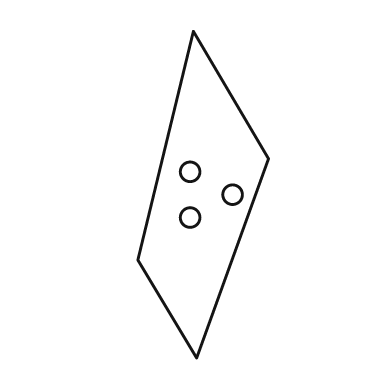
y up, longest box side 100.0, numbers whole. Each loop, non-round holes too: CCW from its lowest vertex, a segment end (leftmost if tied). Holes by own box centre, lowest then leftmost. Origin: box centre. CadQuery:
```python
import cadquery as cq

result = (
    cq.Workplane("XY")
    .moveTo(-2.0, -50.0)
    .lineTo(20.0, 11.0)
    .lineTo(-3.0, 50.0)
    .lineTo(-20.0, -20.0)
    .close()
    .moveTo(-4.0, -7.0)
    .circle(3.0)
    .moveTo(9.0, 0.0)
    .circle(3.0)
    .moveTo(-4.0, 7.0)
    .circle(3.0)
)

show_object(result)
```